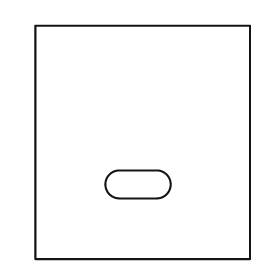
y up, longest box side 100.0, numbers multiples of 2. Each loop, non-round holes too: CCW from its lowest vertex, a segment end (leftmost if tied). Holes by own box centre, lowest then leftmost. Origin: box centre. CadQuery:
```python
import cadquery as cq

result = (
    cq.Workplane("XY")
    .moveTo(-46.0, -50.0)
    .lineTo(46.0, -50.0)
    .lineTo(46.0, 50.0)
    .lineTo(-46.0, 50.0)
    .close()
    .moveTo(-10.0, -24.0)
    .lineTo(6.0, -24.0)
    .threePointArc((12.0, -18.0), (6.0, -12.0))
    .lineTo(-10.0, -12.0)
    .threePointArc((-16.0, -18.0), (-10.0, -24.0))
    .close()
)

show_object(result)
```